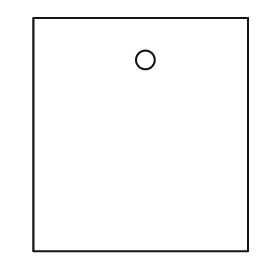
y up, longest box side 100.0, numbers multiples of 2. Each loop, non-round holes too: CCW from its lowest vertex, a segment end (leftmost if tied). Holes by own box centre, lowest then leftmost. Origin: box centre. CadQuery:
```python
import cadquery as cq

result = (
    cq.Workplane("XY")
    .moveTo(-46.0, -50.0)
    .lineTo(46.0, -50.0)
    .lineTo(46.0, 50.0)
    .lineTo(-46.0, 50.0)
    .close()
    .moveTo(2.0, 32.0)
    .circle(4.0)
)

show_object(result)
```